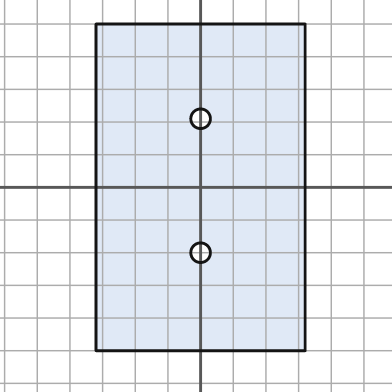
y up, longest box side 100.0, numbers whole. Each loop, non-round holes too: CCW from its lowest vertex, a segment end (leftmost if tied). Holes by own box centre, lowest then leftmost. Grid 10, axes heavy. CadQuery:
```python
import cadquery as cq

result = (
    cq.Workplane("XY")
    .moveTo(-32.0, -50.0)
    .lineTo(32.0, -50.0)
    .lineTo(32.0, 50.0)
    .lineTo(-32.0, 50.0)
    .close()
    .moveTo(0.0, -20.0)
    .circle(3.0)
    .moveTo(0.0, 21.0)
    .circle(3.0)
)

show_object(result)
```